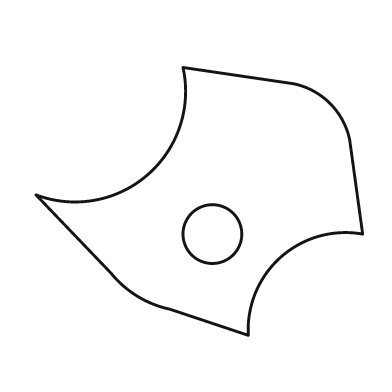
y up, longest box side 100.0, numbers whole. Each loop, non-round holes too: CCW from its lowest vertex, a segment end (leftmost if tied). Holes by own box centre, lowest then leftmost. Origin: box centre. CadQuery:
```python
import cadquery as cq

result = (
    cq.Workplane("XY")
    .moveTo(15.0, -41.0)
    .threePointArc((25.0, -17.0), (50.0, -10.0))
    .lineTo(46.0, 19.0)
    .threePointArc((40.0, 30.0), (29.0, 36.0))
    .lineTo(-5.0, 41.0)
    .threePointArc((-16.0, 8.0), (-50.0, 2.0))
    .lineTo(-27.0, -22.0)
    .threePointArc((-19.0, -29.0), (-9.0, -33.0))
    .close()
    .moveTo(4.0, -10.0)
    .circle(9.0)
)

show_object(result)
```